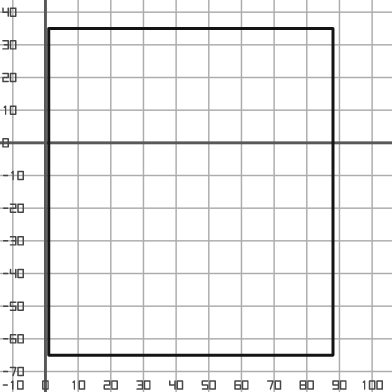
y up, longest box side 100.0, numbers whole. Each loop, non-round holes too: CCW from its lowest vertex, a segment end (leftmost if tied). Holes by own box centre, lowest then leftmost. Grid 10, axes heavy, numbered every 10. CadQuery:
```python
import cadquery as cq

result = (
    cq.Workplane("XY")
    .moveTo(1.0, -65.0)
    .lineTo(88.0, -65.0)
    .lineTo(88.0, 35.0)
    .lineTo(1.0, 35.0)
    .close()
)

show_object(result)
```